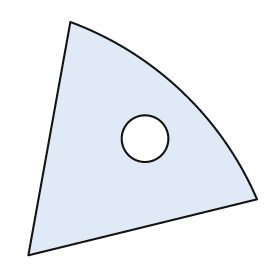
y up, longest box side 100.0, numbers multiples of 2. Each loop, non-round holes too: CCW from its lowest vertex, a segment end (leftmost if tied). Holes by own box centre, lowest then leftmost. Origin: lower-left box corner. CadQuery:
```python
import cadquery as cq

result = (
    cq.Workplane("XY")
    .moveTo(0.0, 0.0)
    .lineTo(98.0, 24.0)
    .threePointArc((66.0, 70.0), (18.0, 100.0))
    .close()
    .moveTo(50.0, 50.0)
    .circle(10.0)
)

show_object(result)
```